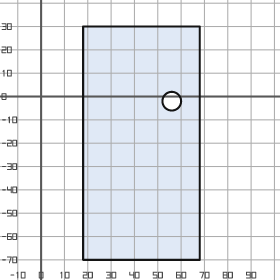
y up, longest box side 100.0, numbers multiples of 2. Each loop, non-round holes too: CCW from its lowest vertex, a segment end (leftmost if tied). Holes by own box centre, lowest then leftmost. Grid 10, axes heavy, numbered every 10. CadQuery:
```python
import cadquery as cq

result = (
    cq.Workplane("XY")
    .moveTo(18.0, -70.0)
    .lineTo(68.0, -70.0)
    .lineTo(68.0, 30.0)
    .lineTo(18.0, 30.0)
    .close()
    .moveTo(56.0, -2.0)
    .circle(4.0)
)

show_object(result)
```